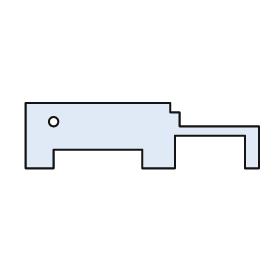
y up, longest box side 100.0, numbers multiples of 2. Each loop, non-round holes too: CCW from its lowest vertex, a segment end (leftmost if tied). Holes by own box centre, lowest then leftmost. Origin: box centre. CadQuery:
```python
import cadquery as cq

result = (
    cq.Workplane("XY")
    .moveTo(-50.0, -14.0)
    .lineTo(-38.0, -14.0)
    .lineTo(-38.0, -6.0)
    .lineTo(0.0, -6.0)
    .lineTo(0.0, -14.0)
    .lineTo(14.0, -14.0)
    .lineTo(14.0, 0.0)
    .lineTo(44.0, 0.0)
    .lineTo(44.0, -14.0)
    .lineTo(50.0, -14.0)
    .lineTo(50.0, 4.0)
    .lineTo(16.0, 4.0)
    .lineTo(16.0, 10.0)
    .lineTo(12.0, 10.0)
    .lineTo(12.0, 14.0)
    .lineTo(-50.0, 14.0)
    .close()
    .moveTo(-38.0, 6.0)
    .circle(2.0)
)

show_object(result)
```